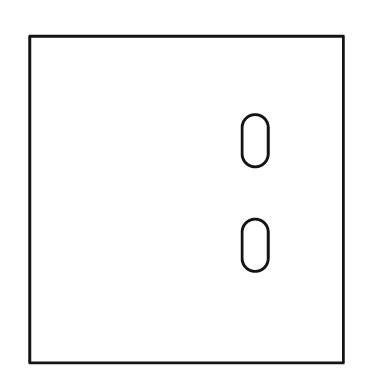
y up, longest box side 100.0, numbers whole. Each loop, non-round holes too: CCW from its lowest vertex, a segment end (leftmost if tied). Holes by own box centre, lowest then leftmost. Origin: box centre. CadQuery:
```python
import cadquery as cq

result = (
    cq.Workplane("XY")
    .moveTo(-48.0, -50.0)
    .lineTo(48.0, -50.0)
    .lineTo(48.0, 50.0)
    .lineTo(-48.0, 50.0)
    .close()
    .moveTo(17.0, -18.0)
    .threePointArc((21.0, -22.0), (25.0, -18.0))
    .lineTo(25.0, -10.0)
    .threePointArc((21.0, -6.0), (17.0, -10.0))
    .close()
    .moveTo(17.0, 14.0)
    .threePointArc((21.0, 10.0), (25.0, 14.0))
    .lineTo(25.0, 22.0)
    .threePointArc((21.0, 26.0), (17.0, 22.0))
    .close()
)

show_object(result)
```